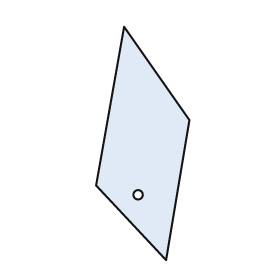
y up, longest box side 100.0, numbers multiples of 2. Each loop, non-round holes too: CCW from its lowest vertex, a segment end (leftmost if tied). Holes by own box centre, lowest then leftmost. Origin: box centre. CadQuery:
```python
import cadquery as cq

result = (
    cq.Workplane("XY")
    .moveTo(10.0, -50.0)
    .lineTo(20.0, 10.0)
    .lineTo(-8.0, 50.0)
    .lineTo(-20.0, -18.0)
    .close()
    .moveTo(-2.0, -22.0)
    .circle(2.0)
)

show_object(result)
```